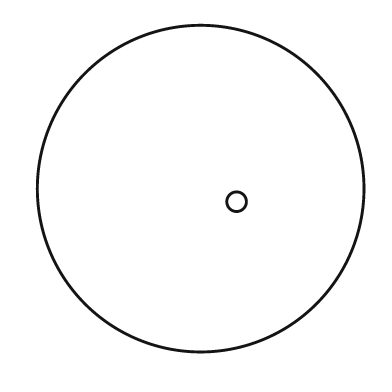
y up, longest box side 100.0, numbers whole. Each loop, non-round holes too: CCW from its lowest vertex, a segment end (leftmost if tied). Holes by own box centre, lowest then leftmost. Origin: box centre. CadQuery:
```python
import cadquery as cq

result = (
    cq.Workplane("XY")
    .moveTo(0.0, 0.0)
    .circle(50.0)
    .moveTo(11.0, -4.0)
    .circle(3.0)
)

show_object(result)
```